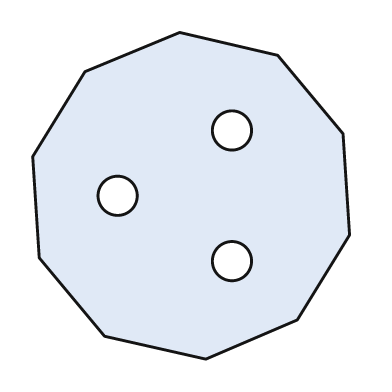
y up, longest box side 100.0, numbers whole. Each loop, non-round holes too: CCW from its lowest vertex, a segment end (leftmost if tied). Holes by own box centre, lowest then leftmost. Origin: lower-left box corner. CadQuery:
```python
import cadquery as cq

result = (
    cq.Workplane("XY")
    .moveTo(53.0, 0.0)
    .lineTo(81.0, 12.0)
    .lineTo(97.0, 38.0)
    .lineTo(95.0, 69.0)
    .lineTo(75.0, 93.0)
    .lineTo(45.0, 100.0)
    .lineTo(16.0, 88.0)
    .lineTo(0.0, 62.0)
    .lineTo(2.0, 31.0)
    .lineTo(22.0, 7.0)
    .close()
    .moveTo(61.0, 30.0)
    .circle(6.0)
    .moveTo(26.0, 50.0)
    .circle(6.0)
    .moveTo(61.0, 70.0)
    .circle(6.0)
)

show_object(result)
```